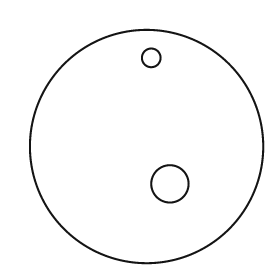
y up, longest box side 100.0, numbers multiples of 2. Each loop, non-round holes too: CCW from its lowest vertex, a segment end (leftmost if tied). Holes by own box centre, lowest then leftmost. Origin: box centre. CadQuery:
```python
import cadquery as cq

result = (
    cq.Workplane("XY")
    .moveTo(0.0, 0.0)
    .circle(50.0)
    .moveTo(10.0, -16.0)
    .circle(8.0)
    .moveTo(2.0, 38.0)
    .circle(4.0)
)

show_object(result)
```